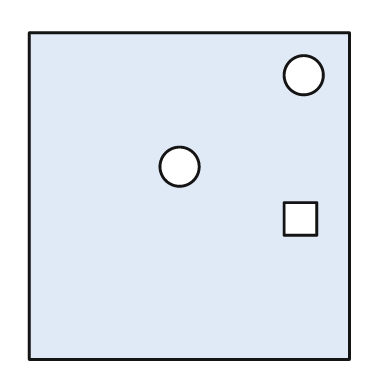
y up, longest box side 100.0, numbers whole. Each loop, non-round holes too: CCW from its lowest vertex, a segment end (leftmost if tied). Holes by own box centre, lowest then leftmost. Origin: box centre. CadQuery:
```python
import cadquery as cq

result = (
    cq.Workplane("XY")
    .moveTo(-49.0, -50.0)
    .lineTo(49.0, -50.0)
    .lineTo(49.0, 50.0)
    .lineTo(-49.0, 50.0)
    .close()
    .moveTo(29.0, -12.0)
    .lineTo(39.0, -12.0)
    .lineTo(39.0, -2.0)
    .lineTo(29.0, -2.0)
    .close()
    .moveTo(-3.0, 9.0)
    .circle(6.0)
    .moveTo(35.0, 37.0)
    .circle(6.0)
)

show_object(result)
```